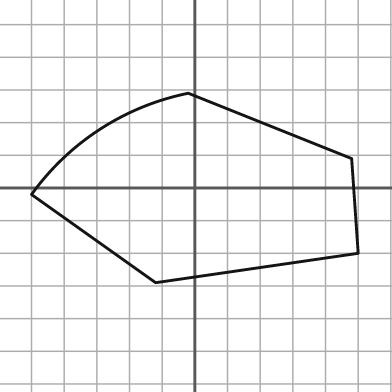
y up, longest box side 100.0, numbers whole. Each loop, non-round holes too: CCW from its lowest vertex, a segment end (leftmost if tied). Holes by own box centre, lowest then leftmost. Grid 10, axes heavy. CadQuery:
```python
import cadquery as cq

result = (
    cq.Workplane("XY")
    .moveTo(-12.0, -29.0)
    .lineTo(50.0, -20.0)
    .lineTo(48.0, 9.0)
    .lineTo(-2.0, 29.0)
    .threePointArc((-29.0, 18.0), (-50.0, -2.0))
    .close()
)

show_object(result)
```